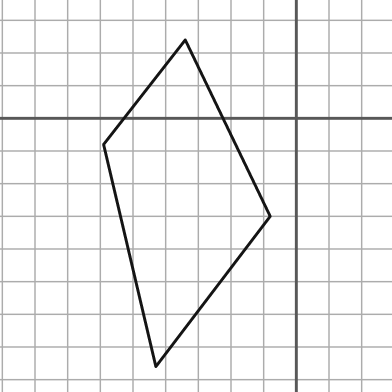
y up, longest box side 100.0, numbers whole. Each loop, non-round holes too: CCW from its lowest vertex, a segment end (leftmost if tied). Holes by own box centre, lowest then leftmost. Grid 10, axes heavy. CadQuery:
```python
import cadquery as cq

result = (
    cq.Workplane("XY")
    .moveTo(-43.0, -76.0)
    .lineTo(-8.0, -30.0)
    .lineTo(-34.0, 24.0)
    .lineTo(-59.0, -8.0)
    .close()
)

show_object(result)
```